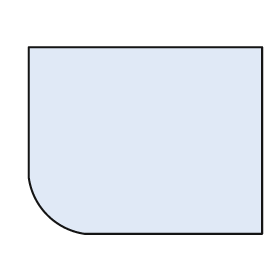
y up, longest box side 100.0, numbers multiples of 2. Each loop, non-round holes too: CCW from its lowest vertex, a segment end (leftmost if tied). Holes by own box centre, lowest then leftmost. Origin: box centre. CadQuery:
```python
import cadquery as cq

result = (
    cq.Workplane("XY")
    .moveTo(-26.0, -40.0)
    .lineTo(50.0, -40.0)
    .lineTo(50.0, 40.0)
    .lineTo(-50.0, 40.0)
    .lineTo(-50.0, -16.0)
    .threePointArc((-42.0, -32.0), (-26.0, -40.0))
    .close()
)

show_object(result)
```